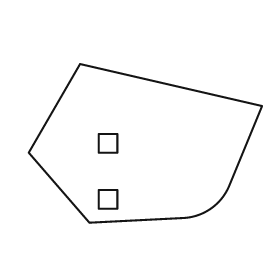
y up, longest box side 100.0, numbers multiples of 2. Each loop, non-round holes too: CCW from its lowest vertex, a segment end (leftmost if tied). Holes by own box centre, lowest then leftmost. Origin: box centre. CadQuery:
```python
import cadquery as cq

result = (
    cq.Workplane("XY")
    .moveTo(-24.0, -34.0)
    .lineTo(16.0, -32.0)
    .threePointArc((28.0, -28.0), (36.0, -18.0))
    .lineTo(50.0, 16.0)
    .lineTo(-28.0, 34.0)
    .lineTo(-50.0, -4.0)
    .close()
    .moveTo(-20.0, -28.0)
    .lineTo(-12.0, -28.0)
    .lineTo(-12.0, -20.0)
    .lineTo(-20.0, -20.0)
    .close()
    .moveTo(-20.0, -4.0)
    .lineTo(-12.0, -4.0)
    .lineTo(-12.0, 4.0)
    .lineTo(-20.0, 4.0)
    .close()
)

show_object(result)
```